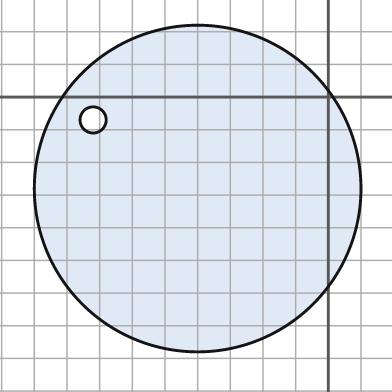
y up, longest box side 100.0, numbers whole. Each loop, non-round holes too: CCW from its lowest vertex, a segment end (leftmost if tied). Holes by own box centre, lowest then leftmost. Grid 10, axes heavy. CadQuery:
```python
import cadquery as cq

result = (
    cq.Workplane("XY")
    .moveTo(-40.0, -28.0)
    .circle(50.0)
    .moveTo(-72.0, -7.0)
    .circle(4.0)
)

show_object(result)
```